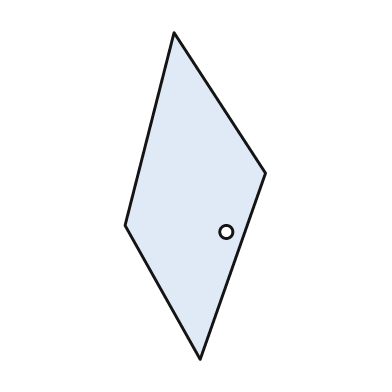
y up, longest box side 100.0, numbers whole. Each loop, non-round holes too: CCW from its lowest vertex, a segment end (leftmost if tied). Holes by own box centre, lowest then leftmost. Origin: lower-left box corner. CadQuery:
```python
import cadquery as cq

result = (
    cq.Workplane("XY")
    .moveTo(23.0, 0.0)
    .lineTo(43.0, 57.0)
    .lineTo(15.0, 100.0)
    .lineTo(0.0, 41.0)
    .close()
    .moveTo(31.0, 39.0)
    .circle(2.0)
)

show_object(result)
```